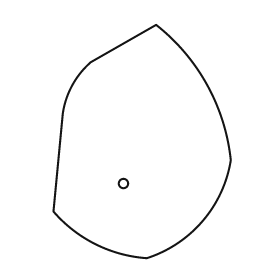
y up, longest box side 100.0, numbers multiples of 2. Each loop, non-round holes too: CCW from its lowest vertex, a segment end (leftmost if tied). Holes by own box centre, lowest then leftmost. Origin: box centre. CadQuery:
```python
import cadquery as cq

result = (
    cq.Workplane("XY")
    .moveTo(2.0, -50.0)
    .threePointArc((26.0, -34.0), (38.0, -8.0))
    .threePointArc((28.0, 24.0), (6.0, 50.0))
    .lineTo(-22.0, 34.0)
    .threePointArc((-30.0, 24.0), (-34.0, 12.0))
    .lineTo(-38.0, -30.0)
    .threePointArc((-20.0, -44.0), (2.0, -50.0))
    .close()
    .moveTo(-8.0, -18.0)
    .circle(2.0)
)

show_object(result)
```